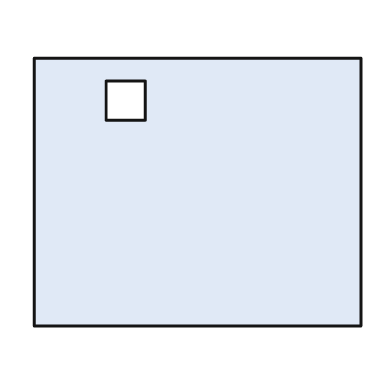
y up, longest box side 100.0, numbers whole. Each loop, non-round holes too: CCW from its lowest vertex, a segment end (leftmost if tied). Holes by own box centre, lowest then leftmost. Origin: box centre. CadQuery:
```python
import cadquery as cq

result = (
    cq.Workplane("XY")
    .moveTo(-50.0, -41.0)
    .lineTo(50.0, -41.0)
    .lineTo(50.0, 41.0)
    .lineTo(-50.0, 41.0)
    .close()
    .moveTo(-28.0, 22.0)
    .lineTo(-16.0, 22.0)
    .lineTo(-16.0, 34.0)
    .lineTo(-28.0, 34.0)
    .close()
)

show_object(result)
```